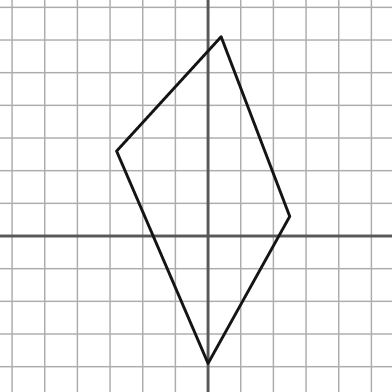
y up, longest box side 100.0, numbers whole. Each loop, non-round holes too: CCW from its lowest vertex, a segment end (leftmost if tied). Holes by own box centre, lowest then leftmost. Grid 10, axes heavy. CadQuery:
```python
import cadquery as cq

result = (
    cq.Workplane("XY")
    .moveTo(0.0, -39.0)
    .lineTo(25.0, 6.0)
    .lineTo(4.0, 61.0)
    .lineTo(-28.0, 26.0)
    .close()
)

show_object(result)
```